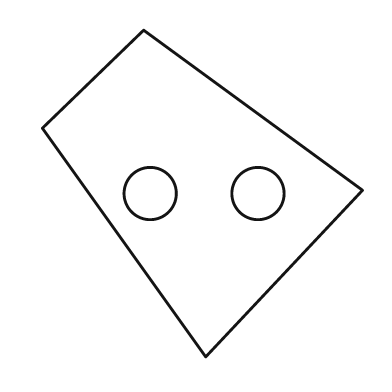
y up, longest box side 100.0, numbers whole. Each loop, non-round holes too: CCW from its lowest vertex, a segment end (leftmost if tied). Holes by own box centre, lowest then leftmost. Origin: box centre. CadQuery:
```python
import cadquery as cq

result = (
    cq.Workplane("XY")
    .moveTo(1.0, -50.0)
    .lineTo(49.0, 1.0)
    .lineTo(-18.0, 50.0)
    .lineTo(-49.0, 20.0)
    .close()
    .moveTo(-16.0, 0.0)
    .circle(8.0)
    .moveTo(17.0, 0.0)
    .circle(8.0)
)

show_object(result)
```